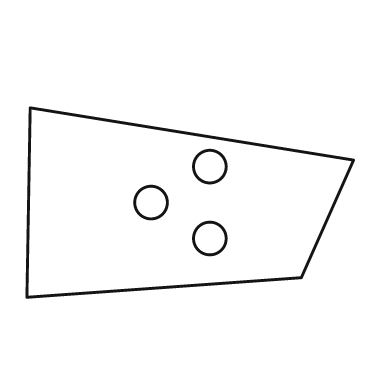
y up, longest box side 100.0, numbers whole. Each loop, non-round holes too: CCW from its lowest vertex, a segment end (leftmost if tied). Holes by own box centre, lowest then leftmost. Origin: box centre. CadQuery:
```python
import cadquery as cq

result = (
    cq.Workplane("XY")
    .moveTo(-50.0, -29.0)
    .lineTo(34.0, -23.0)
    .lineTo(50.0, 13.0)
    .lineTo(-49.0, 29.0)
    .close()
    .moveTo(6.0, -11.0)
    .circle(5.0)
    .moveTo(-12.0, 0.0)
    .circle(5.0)
    .moveTo(6.0, 11.0)
    .circle(5.0)
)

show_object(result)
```